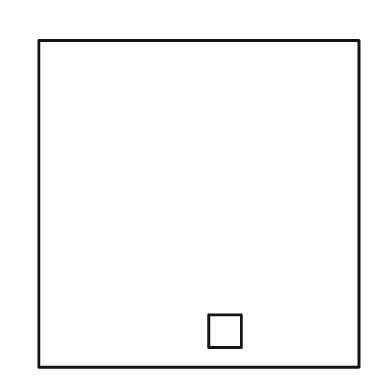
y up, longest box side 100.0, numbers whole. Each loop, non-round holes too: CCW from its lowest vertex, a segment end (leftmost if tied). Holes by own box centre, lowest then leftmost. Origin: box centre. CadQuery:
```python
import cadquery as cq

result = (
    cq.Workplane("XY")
    .moveTo(-49.0, -50.0)
    .lineTo(49.0, -50.0)
    .lineTo(49.0, 50.0)
    .lineTo(-49.0, 50.0)
    .close()
    .moveTo(3.0, -44.0)
    .lineTo(13.0, -44.0)
    .lineTo(13.0, -34.0)
    .lineTo(3.0, -34.0)
    .close()
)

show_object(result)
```